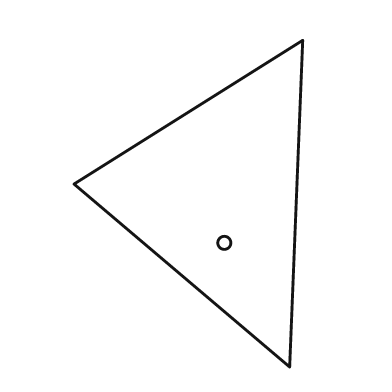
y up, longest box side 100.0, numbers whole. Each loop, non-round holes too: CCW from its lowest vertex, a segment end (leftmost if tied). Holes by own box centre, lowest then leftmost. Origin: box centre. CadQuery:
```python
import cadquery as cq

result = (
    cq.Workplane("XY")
    .moveTo(31.0, -50.0)
    .lineTo(35.0, 50.0)
    .lineTo(-35.0, 6.0)
    .close()
    .moveTo(11.0, -12.0)
    .circle(2.0)
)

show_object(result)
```